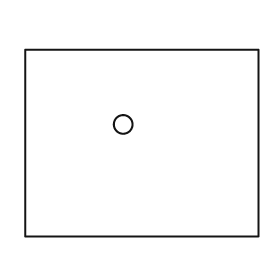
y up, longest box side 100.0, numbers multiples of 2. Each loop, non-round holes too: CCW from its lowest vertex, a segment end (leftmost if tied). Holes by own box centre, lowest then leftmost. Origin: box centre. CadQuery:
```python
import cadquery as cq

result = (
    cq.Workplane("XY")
    .moveTo(-50.0, -40.0)
    .lineTo(50.0, -40.0)
    .lineTo(50.0, 40.0)
    .lineTo(-50.0, 40.0)
    .close()
    .moveTo(-8.0, 8.0)
    .circle(4.0)
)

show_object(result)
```